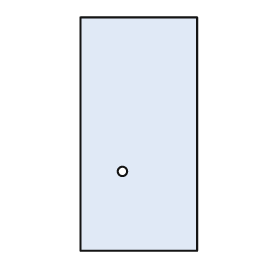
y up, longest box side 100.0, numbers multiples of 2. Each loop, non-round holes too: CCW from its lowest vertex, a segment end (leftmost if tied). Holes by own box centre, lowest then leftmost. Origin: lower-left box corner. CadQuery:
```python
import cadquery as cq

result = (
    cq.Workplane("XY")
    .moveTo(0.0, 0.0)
    .lineTo(50.0, 0.0)
    .lineTo(50.0, 100.0)
    .lineTo(0.0, 100.0)
    .close()
    .moveTo(18.0, 34.0)
    .circle(2.0)
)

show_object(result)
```